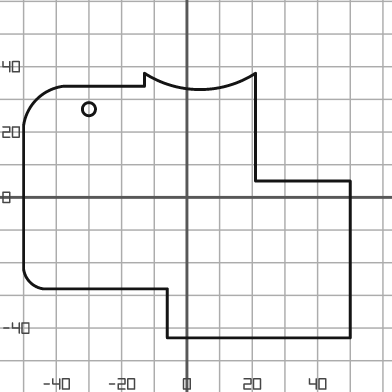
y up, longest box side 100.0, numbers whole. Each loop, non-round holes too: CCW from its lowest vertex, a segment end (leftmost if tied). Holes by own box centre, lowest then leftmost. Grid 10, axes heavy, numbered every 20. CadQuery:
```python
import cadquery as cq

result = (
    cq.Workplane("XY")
    .moveTo(-6.0, -43.0)
    .lineTo(50.0, -43.0)
    .lineTo(50.0, 5.0)
    .lineTo(21.0, 5.0)
    .lineTo(21.0, 38.0)
    .threePointArc((4.0, 33.0), (-13.0, 38.0))
    .lineTo(-13.0, 34.0)
    .lineTo(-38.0, 34.0)
    .threePointArc((-46.0, 30.0), (-50.0, 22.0))
    .lineTo(-50.0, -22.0)
    .threePointArc((-48.0, -26.0), (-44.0, -28.0))
    .lineTo(-6.0, -28.0)
    .close()
    .moveTo(-30.0, 27.0)
    .circle(2.0)
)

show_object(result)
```